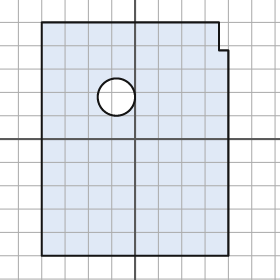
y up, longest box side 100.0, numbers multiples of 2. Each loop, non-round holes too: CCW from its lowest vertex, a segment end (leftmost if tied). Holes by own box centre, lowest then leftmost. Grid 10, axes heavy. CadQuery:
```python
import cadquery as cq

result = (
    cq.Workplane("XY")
    .moveTo(-40.0, -50.0)
    .lineTo(40.0, -50.0)
    .lineTo(40.0, 38.0)
    .lineTo(36.0, 38.0)
    .lineTo(36.0, 50.0)
    .lineTo(-40.0, 50.0)
    .close()
    .moveTo(-8.0, 18.0)
    .circle(8.0)
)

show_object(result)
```